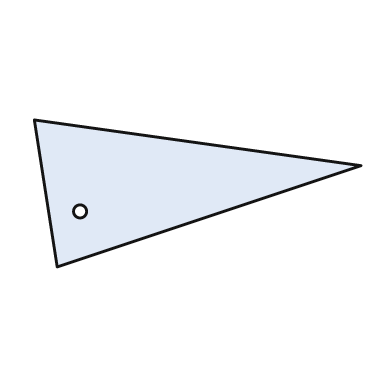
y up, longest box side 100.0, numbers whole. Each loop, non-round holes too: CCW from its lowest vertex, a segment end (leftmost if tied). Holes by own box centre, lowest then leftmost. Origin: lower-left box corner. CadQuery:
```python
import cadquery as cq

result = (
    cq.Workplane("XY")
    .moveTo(7.0, 0.0)
    .lineTo(100.0, 31.0)
    .lineTo(0.0, 45.0)
    .close()
    .moveTo(14.0, 17.0)
    .circle(2.0)
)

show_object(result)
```